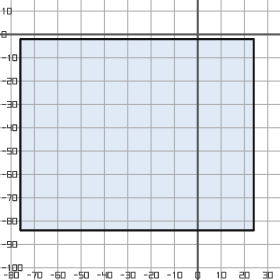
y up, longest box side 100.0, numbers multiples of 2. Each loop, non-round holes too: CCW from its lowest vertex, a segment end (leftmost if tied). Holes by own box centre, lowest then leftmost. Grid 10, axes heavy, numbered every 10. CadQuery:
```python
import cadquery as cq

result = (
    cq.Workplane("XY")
    .moveTo(-76.0, -84.0)
    .lineTo(24.0, -84.0)
    .lineTo(24.0, -2.0)
    .lineTo(-76.0, -2.0)
    .close()
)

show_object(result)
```